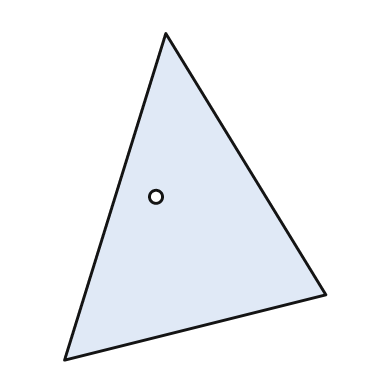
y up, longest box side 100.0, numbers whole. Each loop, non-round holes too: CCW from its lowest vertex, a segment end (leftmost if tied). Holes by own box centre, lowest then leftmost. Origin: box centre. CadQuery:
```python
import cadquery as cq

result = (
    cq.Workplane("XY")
    .moveTo(-40.0, -50.0)
    .lineTo(40.0, -30.0)
    .lineTo(-9.0, 50.0)
    .close()
    .moveTo(-12.0, 0.0)
    .circle(2.0)
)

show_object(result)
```